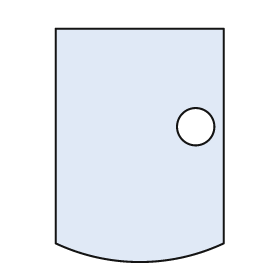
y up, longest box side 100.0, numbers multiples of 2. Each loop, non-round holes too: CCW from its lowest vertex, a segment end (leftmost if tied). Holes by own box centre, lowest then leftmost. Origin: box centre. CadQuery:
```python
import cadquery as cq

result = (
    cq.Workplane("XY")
    .moveTo(-36.0, -42.0)
    .threePointArc((0.0, -50.0), (36.0, -42.0))
    .lineTo(36.0, 50.0)
    .lineTo(-36.0, 50.0)
    .close()
    .moveTo(24.0, 8.0)
    .circle(8.0)
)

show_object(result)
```